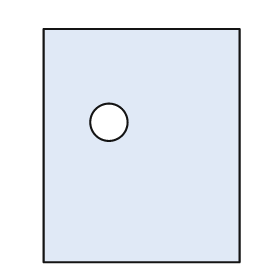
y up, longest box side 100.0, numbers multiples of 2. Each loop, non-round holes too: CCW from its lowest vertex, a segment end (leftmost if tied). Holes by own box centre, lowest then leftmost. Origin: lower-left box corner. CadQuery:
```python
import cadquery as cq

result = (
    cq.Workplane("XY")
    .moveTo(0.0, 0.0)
    .lineTo(84.0, 0.0)
    .lineTo(84.0, 100.0)
    .lineTo(0.0, 100.0)
    .close()
    .moveTo(28.0, 60.0)
    .circle(8.0)
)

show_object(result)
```